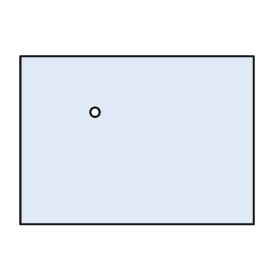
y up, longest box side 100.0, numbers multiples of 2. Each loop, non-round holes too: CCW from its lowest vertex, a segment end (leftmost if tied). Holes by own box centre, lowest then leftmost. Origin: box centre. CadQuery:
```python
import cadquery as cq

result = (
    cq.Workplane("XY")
    .moveTo(-50.0, -36.0)
    .lineTo(50.0, -36.0)
    .lineTo(50.0, 36.0)
    .lineTo(-50.0, 36.0)
    .close()
    .moveTo(-18.0, 12.0)
    .circle(2.0)
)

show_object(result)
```